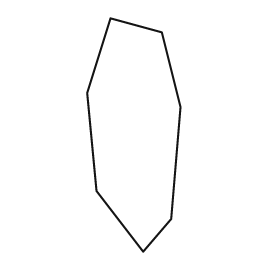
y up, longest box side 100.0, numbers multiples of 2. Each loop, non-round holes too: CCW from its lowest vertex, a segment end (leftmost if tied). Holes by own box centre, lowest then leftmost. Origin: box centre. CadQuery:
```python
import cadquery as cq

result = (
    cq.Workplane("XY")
    .moveTo(4.0, -50.0)
    .lineTo(16.0, -36.0)
    .lineTo(20.0, 12.0)
    .lineTo(12.0, 44.0)
    .lineTo(-10.0, 50.0)
    .lineTo(-20.0, 18.0)
    .lineTo(-16.0, -24.0)
    .close()
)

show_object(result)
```